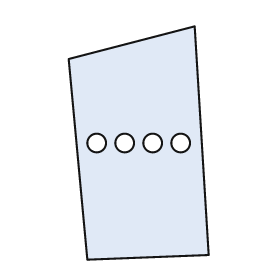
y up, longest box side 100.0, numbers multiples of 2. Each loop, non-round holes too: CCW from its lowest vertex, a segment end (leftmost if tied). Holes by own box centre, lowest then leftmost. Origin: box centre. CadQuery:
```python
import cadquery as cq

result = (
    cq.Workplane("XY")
    .moveTo(-22.0, -50.0)
    .lineTo(30.0, -48.0)
    .lineTo(24.0, 50.0)
    .lineTo(-30.0, 36.0)
    .close()
    .moveTo(-18.0, 0.0)
    .circle(4.0)
    .moveTo(-6.0, 0.0)
    .circle(4.0)
    .moveTo(6.0, 0.0)
    .circle(4.0)
    .moveTo(18.0, 0.0)
    .circle(4.0)
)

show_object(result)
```